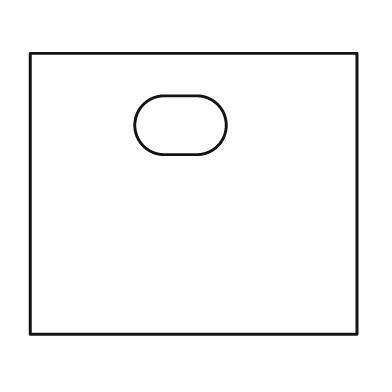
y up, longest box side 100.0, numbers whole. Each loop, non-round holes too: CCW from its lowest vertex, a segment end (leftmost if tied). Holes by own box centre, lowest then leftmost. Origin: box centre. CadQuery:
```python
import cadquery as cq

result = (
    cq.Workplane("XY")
    .moveTo(-50.0, -43.0)
    .lineTo(50.0, -43.0)
    .lineTo(50.0, 43.0)
    .lineTo(-50.0, 43.0)
    .close()
    .moveTo(-9.0, 12.0)
    .lineTo(1.0, 12.0)
    .threePointArc((10.0, 21.0), (1.0, 30.0))
    .lineTo(-9.0, 30.0)
    .threePointArc((-18.0, 21.0), (-9.0, 12.0))
    .close()
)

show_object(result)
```